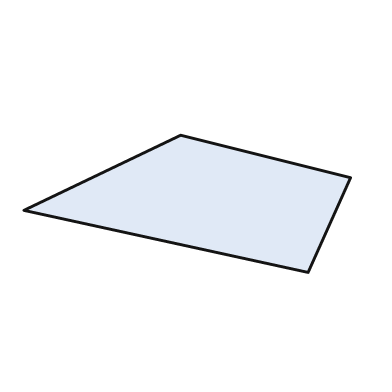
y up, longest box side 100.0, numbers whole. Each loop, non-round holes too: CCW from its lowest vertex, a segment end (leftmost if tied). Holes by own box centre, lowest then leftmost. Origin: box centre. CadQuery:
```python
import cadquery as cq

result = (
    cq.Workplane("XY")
    .moveTo(37.0, -21.0)
    .lineTo(50.0, 8.0)
    .lineTo(-2.0, 21.0)
    .lineTo(-50.0, -2.0)
    .close()
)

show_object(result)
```